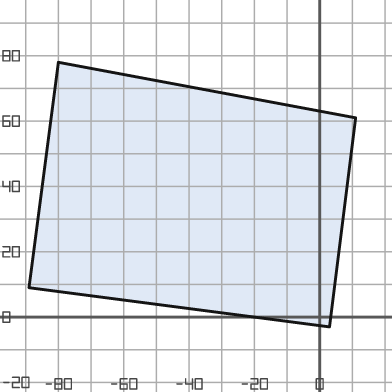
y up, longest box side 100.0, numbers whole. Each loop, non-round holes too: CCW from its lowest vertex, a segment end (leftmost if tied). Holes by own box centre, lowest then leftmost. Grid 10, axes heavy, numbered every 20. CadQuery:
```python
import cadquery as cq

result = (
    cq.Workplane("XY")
    .moveTo(3.0, -3.0)
    .lineTo(11.0, 61.0)
    .lineTo(-80.0, 78.0)
    .lineTo(-89.0, 9.0)
    .close()
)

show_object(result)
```